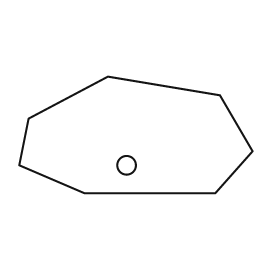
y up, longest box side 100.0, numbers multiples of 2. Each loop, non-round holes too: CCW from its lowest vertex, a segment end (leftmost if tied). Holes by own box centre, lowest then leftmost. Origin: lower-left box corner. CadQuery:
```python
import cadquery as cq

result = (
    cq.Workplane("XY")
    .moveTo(28.0, 0.0)
    .lineTo(84.0, 0.0)
    .lineTo(100.0, 18.0)
    .lineTo(86.0, 42.0)
    .lineTo(38.0, 50.0)
    .lineTo(4.0, 32.0)
    .lineTo(0.0, 12.0)
    .close()
    .moveTo(46.0, 12.0)
    .circle(4.0)
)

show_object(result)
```